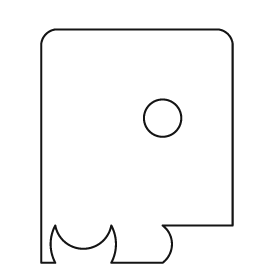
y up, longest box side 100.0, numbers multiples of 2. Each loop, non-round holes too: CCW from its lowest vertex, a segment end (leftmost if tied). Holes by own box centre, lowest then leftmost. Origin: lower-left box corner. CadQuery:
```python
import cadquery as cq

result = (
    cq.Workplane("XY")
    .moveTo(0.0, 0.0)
    .lineTo(6.0, 0.0)
    .threePointArc((4.0, 8.0), (6.0, 16.0))
    .threePointArc((18.0, 6.0), (30.0, 16.0))
    .threePointArc((32.0, 8.0), (30.0, 0.0))
    .lineTo(52.0, 0.0)
    .threePointArc((56.0, 8.0), (52.0, 16.0))
    .lineTo(82.0, 16.0)
    .lineTo(82.0, 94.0)
    .threePointArc((80.0, 98.0), (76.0, 100.0))
    .lineTo(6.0, 100.0)
    .threePointArc((2.0, 98.0), (0.0, 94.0))
    .close()
    .moveTo(52.0, 62.0)
    .circle(8.0)
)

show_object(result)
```